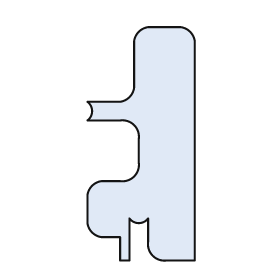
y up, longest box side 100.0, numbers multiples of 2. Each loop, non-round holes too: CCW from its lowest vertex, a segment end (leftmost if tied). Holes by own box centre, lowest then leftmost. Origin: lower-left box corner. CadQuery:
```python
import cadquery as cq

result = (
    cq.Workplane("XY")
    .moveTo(14.0, 0.0)
    .lineTo(18.0, 0.0)
    .lineTo(18.0, 18.0)
    .threePointArc((22.0, 16.0), (26.0, 18.0))
    .lineTo(26.0, 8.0)
    .threePointArc((28.0, 2.0), (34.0, 0.0))
    .lineTo(46.0, 0.0)
    .lineTo(46.0, 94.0)
    .threePointArc((44.0, 98.0), (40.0, 100.0))
    .lineTo(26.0, 100.0)
    .threePointArc((22.0, 98.0), (20.0, 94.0))
    .lineTo(20.0, 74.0)
    .threePointArc((18.0, 70.0), (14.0, 68.0))
    .lineTo(0.0, 68.0)
    .threePointArc((2.0, 64.0), (0.0, 60.0))
    .lineTo(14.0, 60.0)
    .threePointArc((20.0, 58.0), (22.0, 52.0))
    .lineTo(22.0, 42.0)
    .threePointArc((20.0, 36.0), (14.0, 34.0))
    .lineTo(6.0, 34.0)
    .threePointArc((2.0, 32.0), (0.0, 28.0))
    .lineTo(0.0, 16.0)
    .threePointArc((2.0, 12.0), (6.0, 10.0))
    .lineTo(14.0, 10.0)
    .close()
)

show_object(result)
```